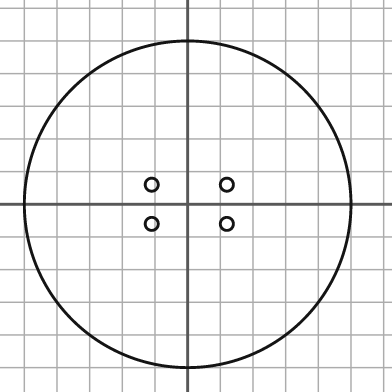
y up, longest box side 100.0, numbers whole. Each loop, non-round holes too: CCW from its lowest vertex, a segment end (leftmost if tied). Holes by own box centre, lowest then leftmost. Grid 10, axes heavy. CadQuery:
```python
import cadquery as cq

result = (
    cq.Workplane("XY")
    .moveTo(0.0, 0.0)
    .circle(50.0)
    .moveTo(-11.0, -6.0)
    .circle(2.0)
    .moveTo(12.0, -6.0)
    .circle(2.0)
    .moveTo(-11.0, 6.0)
    .circle(2.0)
    .moveTo(12.0, 6.0)
    .circle(2.0)
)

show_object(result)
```